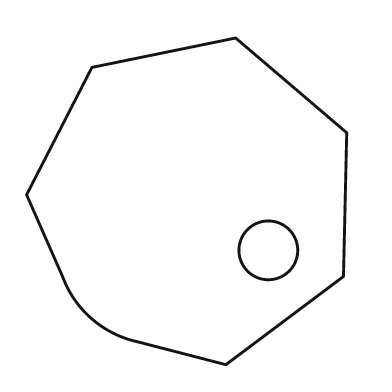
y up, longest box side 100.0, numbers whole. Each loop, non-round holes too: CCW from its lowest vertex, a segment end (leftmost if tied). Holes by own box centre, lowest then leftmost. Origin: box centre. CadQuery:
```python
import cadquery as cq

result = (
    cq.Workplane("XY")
    .moveTo(12.0, -50.0)
    .lineTo(48.0, -23.0)
    .lineTo(49.0, 21.0)
    .lineTo(15.0, 50.0)
    .lineTo(-29.0, 41.0)
    .lineTo(-49.0, 2.0)
    .lineTo(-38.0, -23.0)
    .threePointArc((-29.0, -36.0), (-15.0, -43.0))
    .close()
    .moveTo(25.0, -15.0)
    .circle(9.0)
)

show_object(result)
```